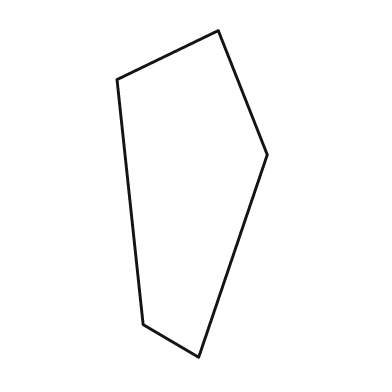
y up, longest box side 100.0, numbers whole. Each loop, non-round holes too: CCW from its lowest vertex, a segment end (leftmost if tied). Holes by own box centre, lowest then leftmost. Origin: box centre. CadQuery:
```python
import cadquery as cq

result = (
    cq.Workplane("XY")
    .moveTo(2.0, -50.0)
    .lineTo(23.0, 12.0)
    .lineTo(8.0, 50.0)
    .lineTo(-23.0, 35.0)
    .lineTo(-15.0, -40.0)
    .close()
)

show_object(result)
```